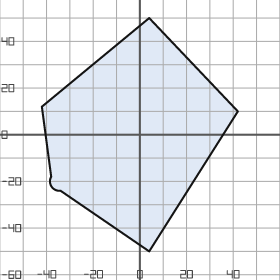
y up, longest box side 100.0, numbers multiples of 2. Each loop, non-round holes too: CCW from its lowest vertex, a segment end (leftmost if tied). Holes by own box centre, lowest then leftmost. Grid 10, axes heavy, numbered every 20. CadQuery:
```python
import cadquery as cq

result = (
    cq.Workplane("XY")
    .moveTo(4.0, -50.0)
    .lineTo(42.0, 10.0)
    .lineTo(4.0, 50.0)
    .lineTo(-42.0, 12.0)
    .lineTo(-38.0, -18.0)
    .threePointArc((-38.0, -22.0), (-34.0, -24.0))
    .close()
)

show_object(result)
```